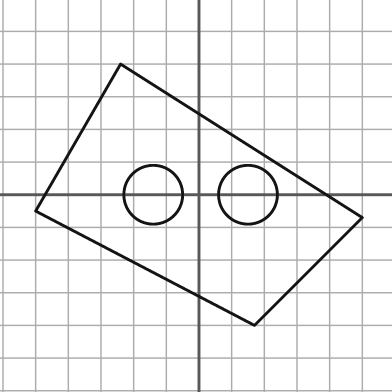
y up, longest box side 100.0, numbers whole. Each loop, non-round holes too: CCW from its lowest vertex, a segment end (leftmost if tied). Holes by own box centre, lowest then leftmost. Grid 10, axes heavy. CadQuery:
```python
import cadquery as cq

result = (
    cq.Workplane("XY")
    .moveTo(17.0, -40.0)
    .lineTo(50.0, -7.0)
    .lineTo(-24.0, 40.0)
    .lineTo(-50.0, -5.0)
    .close()
    .moveTo(-14.0, 0.0)
    .circle(9.0)
    .moveTo(15.0, 0.0)
    .circle(9.0)
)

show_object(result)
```